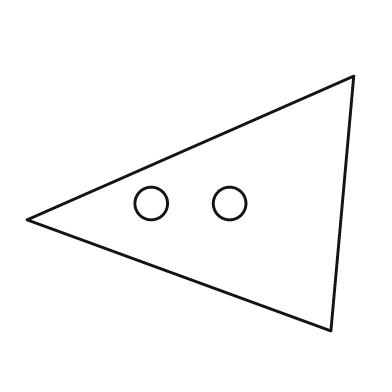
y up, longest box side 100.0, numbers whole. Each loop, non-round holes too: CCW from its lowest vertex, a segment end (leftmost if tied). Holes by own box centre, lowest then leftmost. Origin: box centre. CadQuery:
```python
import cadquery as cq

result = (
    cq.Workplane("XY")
    .moveTo(43.0, -39.0)
    .lineTo(50.0, 39.0)
    .lineTo(-50.0, -5.0)
    .close()
    .moveTo(-12.0, 0.0)
    .circle(5.0)
    .moveTo(12.0, 0.0)
    .circle(5.0)
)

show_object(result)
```